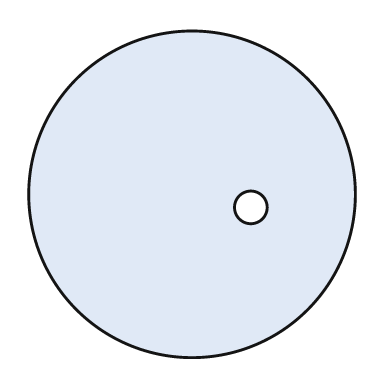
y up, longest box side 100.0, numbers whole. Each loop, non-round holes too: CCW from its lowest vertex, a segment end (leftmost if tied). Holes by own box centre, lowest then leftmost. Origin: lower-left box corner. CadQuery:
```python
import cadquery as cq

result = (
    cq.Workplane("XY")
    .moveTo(50.0, 50.0)
    .circle(50.0)
    .moveTo(68.0, 46.0)
    .circle(5.0)
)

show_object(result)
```